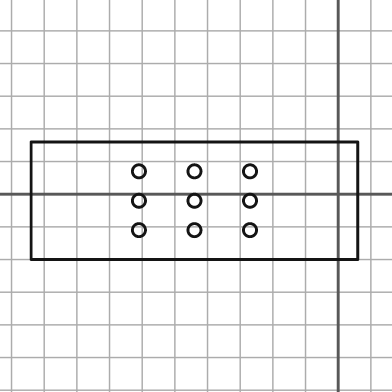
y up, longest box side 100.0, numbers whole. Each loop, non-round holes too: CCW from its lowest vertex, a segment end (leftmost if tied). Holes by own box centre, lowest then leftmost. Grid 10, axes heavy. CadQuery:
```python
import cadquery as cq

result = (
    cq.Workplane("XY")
    .moveTo(-94.0, -20.0)
    .lineTo(6.0, -20.0)
    .lineTo(6.0, 16.0)
    .lineTo(-94.0, 16.0)
    .close()
    .moveTo(-61.0, -11.0)
    .circle(2.0)
    .moveTo(-44.0, -11.0)
    .circle(2.0)
    .moveTo(-27.0, -11.0)
    .circle(2.0)
    .moveTo(-61.0, -2.0)
    .circle(2.0)
    .moveTo(-44.0, -2.0)
    .circle(2.0)
    .moveTo(-27.0, -2.0)
    .circle(2.0)
    .moveTo(-61.0, 7.0)
    .circle(2.0)
    .moveTo(-44.0, 7.0)
    .circle(2.0)
    .moveTo(-27.0, 7.0)
    .circle(2.0)
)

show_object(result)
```